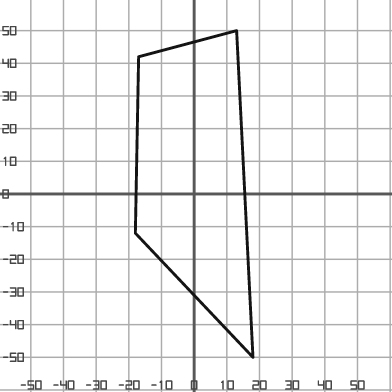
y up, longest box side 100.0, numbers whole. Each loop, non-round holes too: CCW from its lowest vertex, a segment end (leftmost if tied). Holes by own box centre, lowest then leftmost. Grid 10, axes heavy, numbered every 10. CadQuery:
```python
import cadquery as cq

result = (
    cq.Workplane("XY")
    .moveTo(18.0, -50.0)
    .lineTo(13.0, 50.0)
    .lineTo(-17.0, 42.0)
    .lineTo(-18.0, -12.0)
    .close()
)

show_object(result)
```